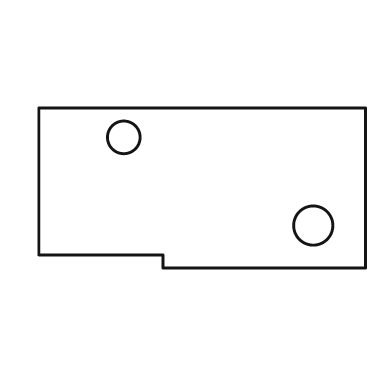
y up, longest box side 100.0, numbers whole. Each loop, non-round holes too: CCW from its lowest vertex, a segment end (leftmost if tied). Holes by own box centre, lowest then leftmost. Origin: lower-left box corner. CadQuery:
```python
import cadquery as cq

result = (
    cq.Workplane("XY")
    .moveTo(38.0, 0.0)
    .lineTo(100.0, 0.0)
    .lineTo(100.0, 49.0)
    .lineTo(0.0, 49.0)
    .lineTo(0.0, 4.0)
    .lineTo(38.0, 4.0)
    .close()
    .moveTo(84.0, 13.0)
    .circle(6.0)
    .moveTo(26.0, 40.0)
    .circle(5.0)
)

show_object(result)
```